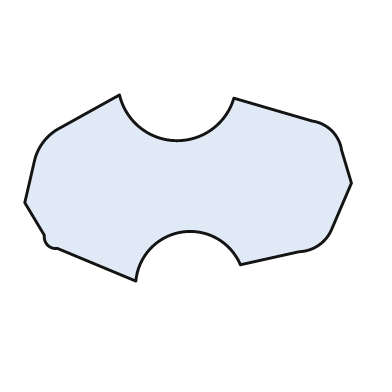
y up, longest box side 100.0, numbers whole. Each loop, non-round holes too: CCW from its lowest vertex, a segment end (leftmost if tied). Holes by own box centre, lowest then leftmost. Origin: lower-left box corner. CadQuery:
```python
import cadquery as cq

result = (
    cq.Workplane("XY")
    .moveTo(34.0, 0.0)
    .threePointArc((48.0, 15.0), (66.0, 5.0))
    .lineTo(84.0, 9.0)
    .threePointArc((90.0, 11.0), (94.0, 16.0))
    .lineTo(100.0, 30.0)
    .lineTo(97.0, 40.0)
    .threePointArc((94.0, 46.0), (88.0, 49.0))
    .lineTo(64.0, 56.0)
    .threePointArc((46.0, 43.0), (29.0, 57.0))
    .lineTo(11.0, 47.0)
    .threePointArc((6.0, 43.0), (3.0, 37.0))
    .lineTo(0.0, 24.0)
    .lineTo(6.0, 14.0)
    .threePointArc((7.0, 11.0), (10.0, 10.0))
    .close()
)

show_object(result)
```